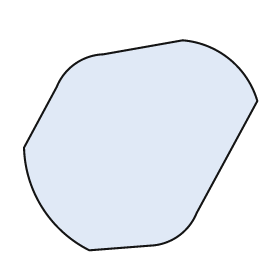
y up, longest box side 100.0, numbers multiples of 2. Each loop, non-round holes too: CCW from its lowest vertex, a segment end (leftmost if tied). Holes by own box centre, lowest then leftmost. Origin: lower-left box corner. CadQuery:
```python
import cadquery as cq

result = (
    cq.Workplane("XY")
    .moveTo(28.0, 0.0)
    .lineTo(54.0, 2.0)
    .threePointArc((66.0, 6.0), (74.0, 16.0))
    .lineTo(100.0, 64.0)
    .threePointArc((88.0, 82.0), (68.0, 90.0))
    .lineTo(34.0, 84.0)
    .threePointArc((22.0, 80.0), (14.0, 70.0))
    .lineTo(0.0, 44.0)
    .threePointArc((8.0, 18.0), (28.0, 0.0))
    .close()
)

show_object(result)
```